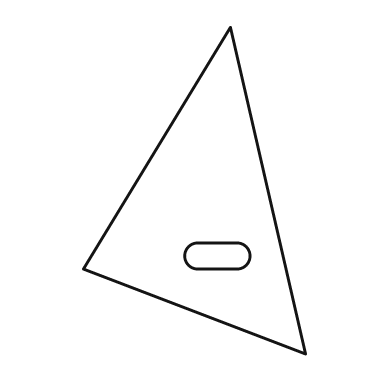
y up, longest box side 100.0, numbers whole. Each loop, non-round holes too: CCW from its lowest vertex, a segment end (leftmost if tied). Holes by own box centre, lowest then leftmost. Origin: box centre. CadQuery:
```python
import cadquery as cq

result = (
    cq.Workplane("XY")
    .moveTo(34.0, -50.0)
    .lineTo(11.0, 50.0)
    .lineTo(-34.0, -24.0)
    .close()
    .moveTo(1.0, -24.0)
    .lineTo(13.0, -24.0)
    .threePointArc((17.0, -20.0), (13.0, -16.0))
    .lineTo(1.0, -16.0)
    .threePointArc((-3.0, -20.0), (1.0, -24.0))
    .close()
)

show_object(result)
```